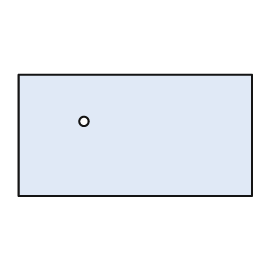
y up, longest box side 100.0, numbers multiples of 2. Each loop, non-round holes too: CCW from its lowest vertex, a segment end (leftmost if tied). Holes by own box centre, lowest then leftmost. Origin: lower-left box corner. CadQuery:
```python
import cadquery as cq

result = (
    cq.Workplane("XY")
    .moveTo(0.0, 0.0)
    .lineTo(100.0, 0.0)
    .lineTo(100.0, 52.0)
    .lineTo(0.0, 52.0)
    .close()
    .moveTo(28.0, 32.0)
    .circle(2.0)
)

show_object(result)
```